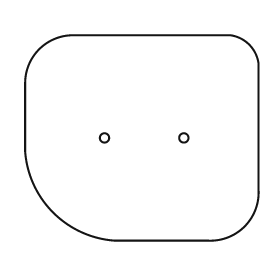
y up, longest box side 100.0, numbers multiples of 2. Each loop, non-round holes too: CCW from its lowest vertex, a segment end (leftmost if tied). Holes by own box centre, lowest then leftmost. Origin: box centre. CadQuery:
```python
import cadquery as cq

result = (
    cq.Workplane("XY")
    .moveTo(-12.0, -44.0)
    .lineTo(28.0, -44.0)
    .threePointArc((44.0, -38.0), (50.0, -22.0))
    .lineTo(50.0, 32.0)
    .threePointArc((46.0, 40.0), (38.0, 44.0))
    .lineTo(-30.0, 44.0)
    .threePointArc((-44.0, 38.0), (-50.0, 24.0))
    .lineTo(-50.0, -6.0)
    .threePointArc((-38.0, -32.0), (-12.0, -44.0))
    .close()
    .moveTo(-16.0, 0.0)
    .circle(2.0)
    .moveTo(18.0, 0.0)
    .circle(2.0)
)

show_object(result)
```